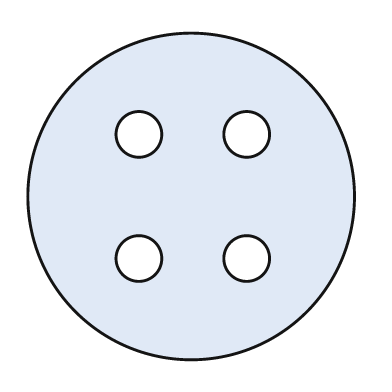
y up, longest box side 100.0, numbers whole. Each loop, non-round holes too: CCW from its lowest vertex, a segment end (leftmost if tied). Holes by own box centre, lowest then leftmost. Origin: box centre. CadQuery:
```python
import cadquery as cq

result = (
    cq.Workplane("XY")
    .moveTo(0.0, 0.0)
    .circle(50.0)
    .moveTo(-16.0, -19.0)
    .circle(7.0)
    .moveTo(17.0, -19.0)
    .circle(7.0)
    .moveTo(-16.0, 19.0)
    .circle(7.0)
    .moveTo(17.0, 19.0)
    .circle(7.0)
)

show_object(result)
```